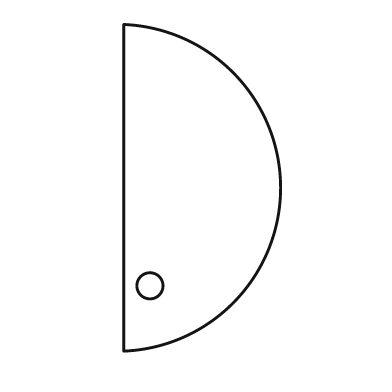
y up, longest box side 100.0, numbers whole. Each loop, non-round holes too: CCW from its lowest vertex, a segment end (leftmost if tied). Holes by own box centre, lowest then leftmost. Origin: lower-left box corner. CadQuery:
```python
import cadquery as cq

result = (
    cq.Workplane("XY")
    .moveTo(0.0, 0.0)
    .threePointArc((48.0, 50.0), (0.0, 100.0))
    .close()
    .moveTo(8.0, 20.0)
    .circle(4.0)
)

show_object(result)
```